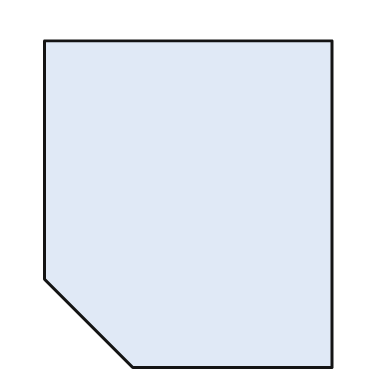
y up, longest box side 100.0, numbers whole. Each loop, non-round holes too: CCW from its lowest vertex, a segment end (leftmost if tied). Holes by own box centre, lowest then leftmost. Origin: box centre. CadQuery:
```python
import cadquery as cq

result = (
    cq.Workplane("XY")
    .moveTo(-17.0, -50.0)
    .lineTo(44.0, -50.0)
    .lineTo(44.0, 50.0)
    .lineTo(-44.0, 50.0)
    .lineTo(-44.0, -23.0)
    .close()
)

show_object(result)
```